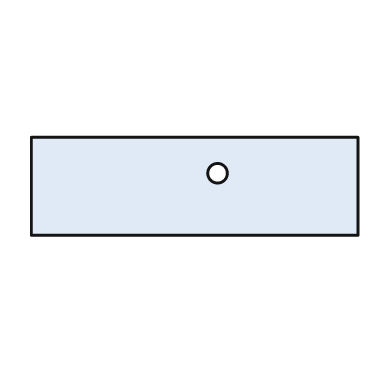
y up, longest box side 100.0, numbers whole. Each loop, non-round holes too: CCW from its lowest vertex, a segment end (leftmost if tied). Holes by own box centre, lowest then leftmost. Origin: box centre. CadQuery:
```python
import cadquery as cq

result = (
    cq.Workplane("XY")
    .moveTo(-50.0, -15.0)
    .lineTo(50.0, -15.0)
    .lineTo(50.0, 15.0)
    .lineTo(-50.0, 15.0)
    .close()
    .moveTo(7.0, 4.0)
    .circle(3.0)
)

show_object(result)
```